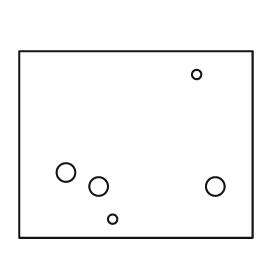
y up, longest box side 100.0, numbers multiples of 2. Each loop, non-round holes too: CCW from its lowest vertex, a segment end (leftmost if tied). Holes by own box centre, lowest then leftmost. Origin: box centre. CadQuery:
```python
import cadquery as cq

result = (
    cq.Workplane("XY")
    .moveTo(-50.0, -40.0)
    .lineTo(50.0, -40.0)
    .lineTo(50.0, 40.0)
    .lineTo(-50.0, 40.0)
    .close()
    .moveTo(-10.0, -32.0)
    .circle(2.0)
    .moveTo(-16.0, -18.0)
    .circle(4.0)
    .moveTo(34.0, -18.0)
    .circle(4.0)
    .moveTo(-30.0, -12.0)
    .circle(4.0)
    .moveTo(26.0, 30.0)
    .circle(2.0)
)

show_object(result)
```